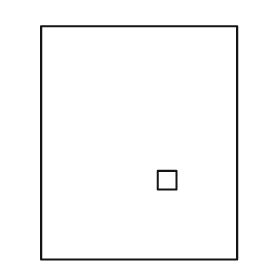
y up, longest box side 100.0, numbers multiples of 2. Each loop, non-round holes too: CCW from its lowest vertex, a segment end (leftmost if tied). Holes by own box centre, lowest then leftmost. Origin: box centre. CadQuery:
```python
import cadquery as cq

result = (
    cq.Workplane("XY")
    .moveTo(-42.0, -50.0)
    .lineTo(42.0, -50.0)
    .lineTo(42.0, 50.0)
    .lineTo(-42.0, 50.0)
    .close()
    .moveTo(8.0, -20.0)
    .lineTo(16.0, -20.0)
    .lineTo(16.0, -12.0)
    .lineTo(8.0, -12.0)
    .close()
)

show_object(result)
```